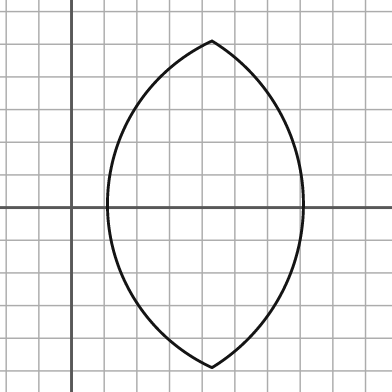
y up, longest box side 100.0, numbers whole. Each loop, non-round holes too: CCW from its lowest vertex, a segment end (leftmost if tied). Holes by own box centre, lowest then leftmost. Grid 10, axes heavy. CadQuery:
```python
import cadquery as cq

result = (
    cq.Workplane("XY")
    .moveTo(43.0, -49.0)
    .threePointArc((71.0, 1.0), (43.0, 51.0))
    .threePointArc((11.0, 1.0), (43.0, -49.0))
    .close()
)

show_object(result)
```